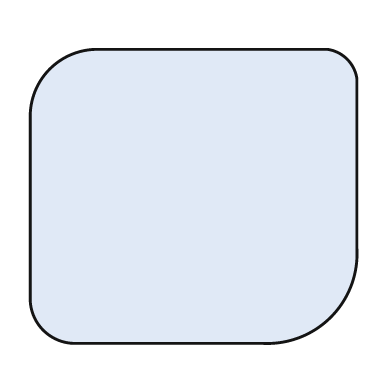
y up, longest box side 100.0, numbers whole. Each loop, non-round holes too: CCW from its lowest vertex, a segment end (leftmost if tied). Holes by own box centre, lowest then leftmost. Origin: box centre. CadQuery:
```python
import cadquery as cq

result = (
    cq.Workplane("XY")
    .moveTo(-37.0, -45.0)
    .lineTo(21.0, -45.0)
    .threePointArc((42.0, -37.0), (50.0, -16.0))
    .lineTo(50.0, 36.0)
    .threePointArc((47.0, 42.0), (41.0, 45.0))
    .lineTo(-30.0, 45.0)
    .threePointArc((-44.0, 39.0), (-50.0, 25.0))
    .lineTo(-50.0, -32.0)
    .threePointArc((-46.0, -41.0), (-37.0, -45.0))
    .close()
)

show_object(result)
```